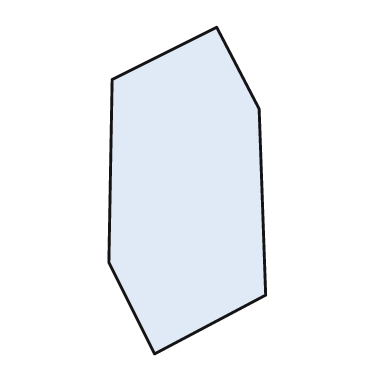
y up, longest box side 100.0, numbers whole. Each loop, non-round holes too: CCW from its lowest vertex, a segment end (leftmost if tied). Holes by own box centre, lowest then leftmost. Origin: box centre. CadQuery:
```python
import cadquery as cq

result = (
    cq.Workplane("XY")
    .moveTo(-10.0, -50.0)
    .lineTo(24.0, -32.0)
    .lineTo(22.0, 25.0)
    .lineTo(9.0, 50.0)
    .lineTo(-23.0, 34.0)
    .lineTo(-24.0, -22.0)
    .close()
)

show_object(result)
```